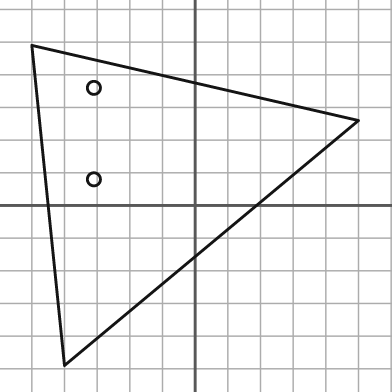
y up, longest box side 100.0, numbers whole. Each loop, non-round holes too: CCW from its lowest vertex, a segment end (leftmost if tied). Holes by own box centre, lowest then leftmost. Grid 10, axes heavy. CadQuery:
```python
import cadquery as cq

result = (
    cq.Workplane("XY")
    .moveTo(-40.0, -49.0)
    .lineTo(50.0, 26.0)
    .lineTo(-50.0, 49.0)
    .close()
    .moveTo(-31.0, 8.0)
    .circle(2.0)
    .moveTo(-31.0, 36.0)
    .circle(2.0)
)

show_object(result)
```